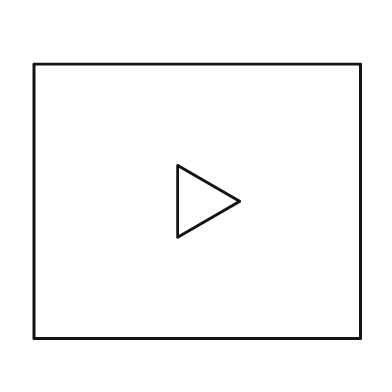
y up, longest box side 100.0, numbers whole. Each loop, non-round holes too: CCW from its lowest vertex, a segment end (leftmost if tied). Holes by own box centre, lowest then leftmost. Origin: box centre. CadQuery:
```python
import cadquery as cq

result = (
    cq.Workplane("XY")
    .moveTo(-50.0, -42.0)
    .lineTo(50.0, -42.0)
    .lineTo(50.0, 42.0)
    .lineTo(-50.0, 42.0)
    .close()
    .moveTo(-6.0, -11.0)
    .lineTo(13.0, 0.0)
    .lineTo(-6.0, 11.0)
    .close()
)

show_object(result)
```